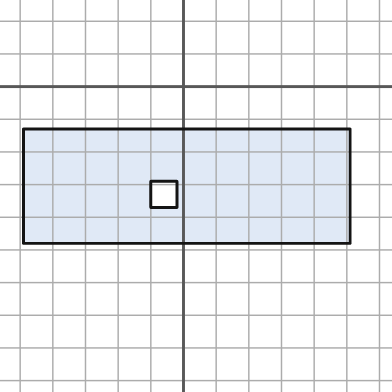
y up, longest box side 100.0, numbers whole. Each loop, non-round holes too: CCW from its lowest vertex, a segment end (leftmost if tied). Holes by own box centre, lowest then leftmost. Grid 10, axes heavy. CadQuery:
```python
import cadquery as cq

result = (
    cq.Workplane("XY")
    .moveTo(-49.0, -48.0)
    .lineTo(51.0, -48.0)
    .lineTo(51.0, -13.0)
    .lineTo(-49.0, -13.0)
    .close()
    .moveTo(-10.0, -37.0)
    .lineTo(-2.0, -37.0)
    .lineTo(-2.0, -29.0)
    .lineTo(-10.0, -29.0)
    .close()
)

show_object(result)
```